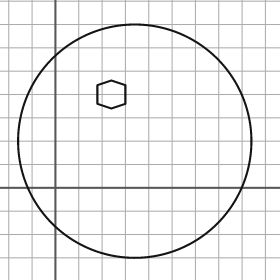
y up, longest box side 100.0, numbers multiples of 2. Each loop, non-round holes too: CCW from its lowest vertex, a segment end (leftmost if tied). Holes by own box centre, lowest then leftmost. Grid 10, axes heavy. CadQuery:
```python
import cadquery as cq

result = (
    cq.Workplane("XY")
    .moveTo(34.0, 20.0)
    .circle(50.0)
    .moveTo(24.0, 34.0)
    .lineTo(30.0, 36.0)
    .lineTo(30.0, 44.0)
    .lineTo(24.0, 46.0)
    .lineTo(18.0, 44.0)
    .lineTo(18.0, 36.0)
    .close()
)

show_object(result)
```